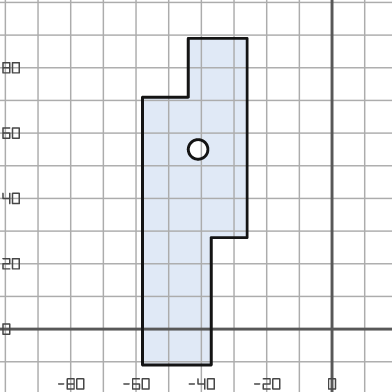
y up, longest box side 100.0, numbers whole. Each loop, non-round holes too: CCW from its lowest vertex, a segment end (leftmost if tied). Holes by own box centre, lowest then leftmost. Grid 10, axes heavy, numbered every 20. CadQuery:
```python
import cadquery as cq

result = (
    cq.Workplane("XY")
    .moveTo(-58.0, -11.0)
    .lineTo(-37.0, -11.0)
    .lineTo(-37.0, 28.0)
    .lineTo(-26.0, 28.0)
    .lineTo(-26.0, 89.0)
    .lineTo(-44.0, 89.0)
    .lineTo(-44.0, 71.0)
    .lineTo(-58.0, 71.0)
    .close()
    .moveTo(-41.0, 55.0)
    .circle(3.0)
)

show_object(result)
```